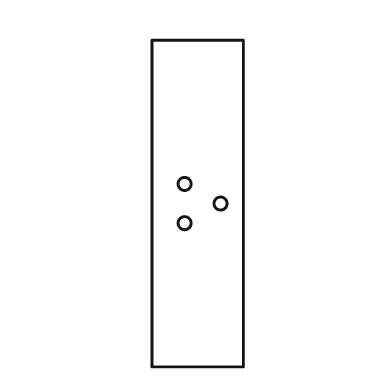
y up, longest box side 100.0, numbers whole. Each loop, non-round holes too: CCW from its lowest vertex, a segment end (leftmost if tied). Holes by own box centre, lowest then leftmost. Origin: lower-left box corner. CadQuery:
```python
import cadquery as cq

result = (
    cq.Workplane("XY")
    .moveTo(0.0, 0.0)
    .lineTo(28.0, 0.0)
    .lineTo(28.0, 100.0)
    .lineTo(0.0, 100.0)
    .close()
    .moveTo(10.0, 44.0)
    .circle(2.0)
    .moveTo(21.0, 50.0)
    .circle(2.0)
    .moveTo(10.0, 56.0)
    .circle(2.0)
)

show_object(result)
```